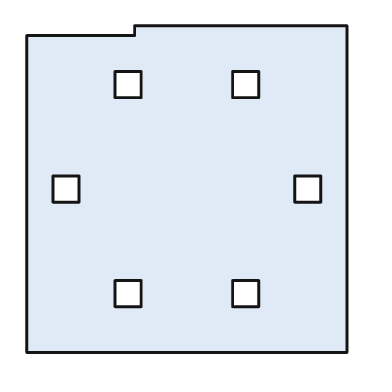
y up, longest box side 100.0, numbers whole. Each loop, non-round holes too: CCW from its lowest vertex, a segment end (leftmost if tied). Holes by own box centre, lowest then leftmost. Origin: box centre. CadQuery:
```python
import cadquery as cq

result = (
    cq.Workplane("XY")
    .moveTo(-49.0, -50.0)
    .lineTo(49.0, -50.0)
    .lineTo(49.0, 50.0)
    .lineTo(-16.0, 50.0)
    .lineTo(-16.0, 47.0)
    .lineTo(-49.0, 47.0)
    .close()
    .moveTo(-22.0, -36.0)
    .lineTo(-14.0, -36.0)
    .lineTo(-14.0, -28.0)
    .lineTo(-22.0, -28.0)
    .close()
    .moveTo(14.0, -36.0)
    .lineTo(22.0, -36.0)
    .lineTo(22.0, -28.0)
    .lineTo(14.0, -28.0)
    .close()
    .moveTo(-41.0, -4.0)
    .lineTo(-33.0, -4.0)
    .lineTo(-33.0, 4.0)
    .lineTo(-41.0, 4.0)
    .close()
    .moveTo(33.0, -4.0)
    .lineTo(41.0, -4.0)
    .lineTo(41.0, 4.0)
    .lineTo(33.0, 4.0)
    .close()
    .moveTo(-22.0, 28.0)
    .lineTo(-14.0, 28.0)
    .lineTo(-14.0, 36.0)
    .lineTo(-22.0, 36.0)
    .close()
    .moveTo(14.0, 28.0)
    .lineTo(22.0, 28.0)
    .lineTo(22.0, 36.0)
    .lineTo(14.0, 36.0)
    .close()
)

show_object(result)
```